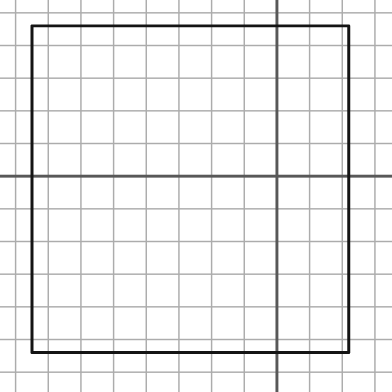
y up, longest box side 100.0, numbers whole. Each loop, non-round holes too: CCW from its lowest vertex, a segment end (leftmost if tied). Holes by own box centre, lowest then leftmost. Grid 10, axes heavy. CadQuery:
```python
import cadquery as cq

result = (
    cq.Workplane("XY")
    .moveTo(-75.0, -54.0)
    .lineTo(22.0, -54.0)
    .lineTo(22.0, 46.0)
    .lineTo(-75.0, 46.0)
    .close()
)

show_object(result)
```